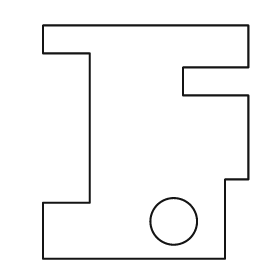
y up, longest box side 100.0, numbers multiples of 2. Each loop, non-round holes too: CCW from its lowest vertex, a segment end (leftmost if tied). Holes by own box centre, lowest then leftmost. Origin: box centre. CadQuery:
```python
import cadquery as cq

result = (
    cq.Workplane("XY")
    .moveTo(-44.0, -50.0)
    .lineTo(34.0, -50.0)
    .lineTo(34.0, -16.0)
    .lineTo(44.0, -16.0)
    .lineTo(44.0, 20.0)
    .lineTo(16.0, 20.0)
    .lineTo(16.0, 32.0)
    .lineTo(44.0, 32.0)
    .lineTo(44.0, 50.0)
    .lineTo(-44.0, 50.0)
    .lineTo(-44.0, 38.0)
    .lineTo(-24.0, 38.0)
    .lineTo(-24.0, -26.0)
    .lineTo(-44.0, -26.0)
    .close()
    .moveTo(12.0, -34.0)
    .circle(10.0)
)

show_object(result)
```